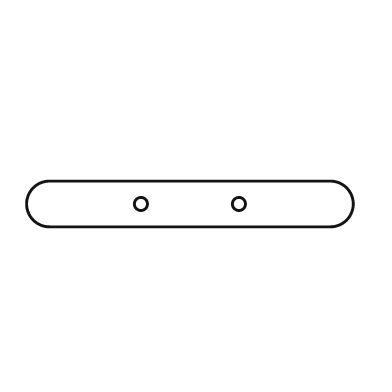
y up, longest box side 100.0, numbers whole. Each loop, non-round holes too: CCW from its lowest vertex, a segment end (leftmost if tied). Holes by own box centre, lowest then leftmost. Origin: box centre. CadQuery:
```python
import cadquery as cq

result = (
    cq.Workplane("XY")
    .moveTo(-43.0, -7.0)
    .lineTo(43.0, -7.0)
    .threePointArc((50.0, 0.0), (43.0, 7.0))
    .lineTo(-43.0, 7.0)
    .threePointArc((-50.0, 0.0), (-43.0, -7.0))
    .close()
    .moveTo(-15.0, 0.0)
    .circle(2.0)
    .moveTo(15.0, 0.0)
    .circle(2.0)
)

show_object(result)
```